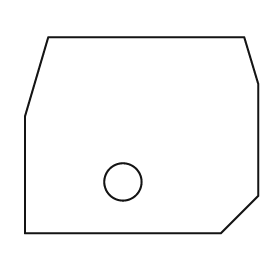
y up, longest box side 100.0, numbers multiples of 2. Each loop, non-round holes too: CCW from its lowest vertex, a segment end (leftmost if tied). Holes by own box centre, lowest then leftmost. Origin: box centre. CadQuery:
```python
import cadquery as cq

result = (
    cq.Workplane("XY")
    .moveTo(-50.0, -42.0)
    .lineTo(34.0, -42.0)
    .lineTo(50.0, -26.0)
    .lineTo(50.0, 22.0)
    .lineTo(44.0, 42.0)
    .lineTo(-40.0, 42.0)
    .lineTo(-50.0, 8.0)
    .close()
    .moveTo(-8.0, -20.0)
    .circle(8.0)
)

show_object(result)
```